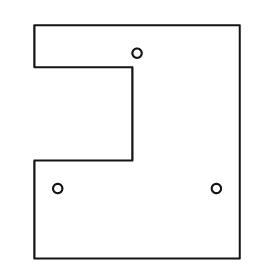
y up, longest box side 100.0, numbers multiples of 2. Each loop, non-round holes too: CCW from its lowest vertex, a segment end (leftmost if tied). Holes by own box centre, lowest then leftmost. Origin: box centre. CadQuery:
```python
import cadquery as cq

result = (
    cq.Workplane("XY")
    .moveTo(-44.0, -50.0)
    .lineTo(44.0, -50.0)
    .lineTo(44.0, 50.0)
    .lineTo(-44.0, 50.0)
    .lineTo(-44.0, 32.0)
    .lineTo(-2.0, 32.0)
    .lineTo(-2.0, -8.0)
    .lineTo(-44.0, -8.0)
    .close()
    .moveTo(-34.0, -20.0)
    .circle(2.0)
    .moveTo(34.0, -20.0)
    .circle(2.0)
    .moveTo(0.0, 38.0)
    .circle(2.0)
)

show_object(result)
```